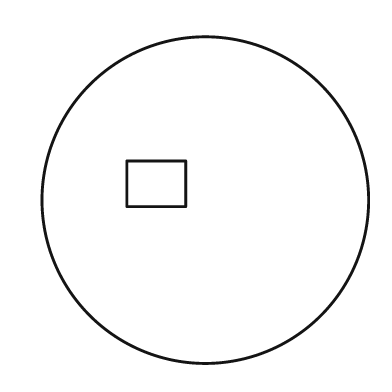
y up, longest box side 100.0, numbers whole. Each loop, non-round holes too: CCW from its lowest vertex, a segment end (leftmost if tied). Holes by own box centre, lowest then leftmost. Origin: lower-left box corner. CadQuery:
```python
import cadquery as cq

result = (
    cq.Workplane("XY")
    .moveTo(50.0, 50.0)
    .circle(50.0)
    .moveTo(26.0, 48.0)
    .lineTo(44.0, 48.0)
    .lineTo(44.0, 62.0)
    .lineTo(26.0, 62.0)
    .close()
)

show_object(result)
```